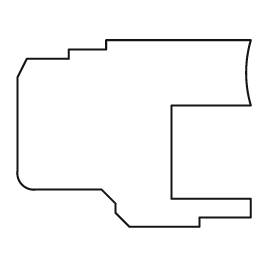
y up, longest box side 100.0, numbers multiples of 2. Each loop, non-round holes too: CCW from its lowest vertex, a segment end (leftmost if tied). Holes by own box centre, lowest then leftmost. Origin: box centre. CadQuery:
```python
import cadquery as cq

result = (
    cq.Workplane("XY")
    .moveTo(-2.0, -40.0)
    .lineTo(28.0, -40.0)
    .lineTo(28.0, -36.0)
    .lineTo(50.0, -36.0)
    .lineTo(50.0, -28.0)
    .lineTo(16.0, -28.0)
    .lineTo(16.0, 12.0)
    .lineTo(50.0, 12.0)
    .threePointArc((48.0, 26.0), (50.0, 40.0))
    .lineTo(-12.0, 40.0)
    .lineTo(-12.0, 36.0)
    .lineTo(-28.0, 36.0)
    .lineTo(-28.0, 32.0)
    .lineTo(-46.0, 32.0)
    .lineTo(-50.0, 24.0)
    .lineTo(-50.0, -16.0)
    .threePointArc((-48.0, -22.0), (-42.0, -24.0))
    .lineTo(-14.0, -24.0)
    .lineTo(-8.0, -30.0)
    .lineTo(-8.0, -34.0)
    .close()
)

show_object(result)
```